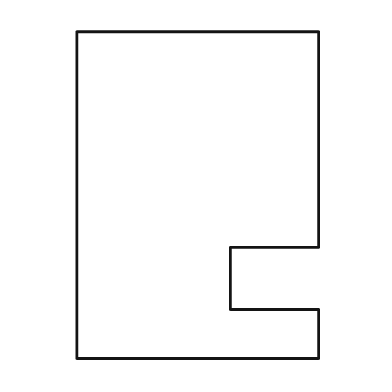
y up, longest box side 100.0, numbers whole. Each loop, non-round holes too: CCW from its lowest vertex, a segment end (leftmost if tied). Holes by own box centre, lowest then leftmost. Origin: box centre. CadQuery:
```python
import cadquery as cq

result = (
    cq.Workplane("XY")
    .moveTo(-37.0, -50.0)
    .lineTo(37.0, -50.0)
    .lineTo(37.0, -35.0)
    .lineTo(10.0, -35.0)
    .lineTo(10.0, -16.0)
    .lineTo(37.0, -16.0)
    .lineTo(37.0, 50.0)
    .lineTo(-37.0, 50.0)
    .close()
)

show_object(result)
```